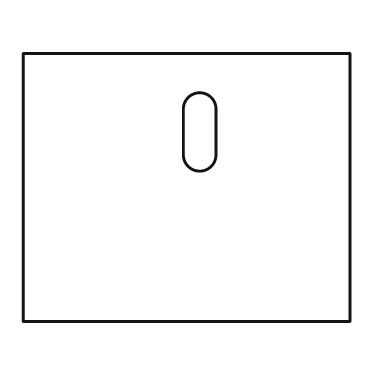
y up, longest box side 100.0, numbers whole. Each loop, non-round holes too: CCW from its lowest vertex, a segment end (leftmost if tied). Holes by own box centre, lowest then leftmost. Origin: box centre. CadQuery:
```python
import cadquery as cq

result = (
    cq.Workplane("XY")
    .moveTo(-50.0, -41.0)
    .lineTo(50.0, -41.0)
    .lineTo(50.0, 41.0)
    .lineTo(-50.0, 41.0)
    .close()
    .moveTo(-1.0, 10.0)
    .threePointArc((4.0, 5.0), (9.0, 10.0))
    .lineTo(9.0, 24.0)
    .threePointArc((4.0, 29.0), (-1.0, 24.0))
    .close()
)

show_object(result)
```